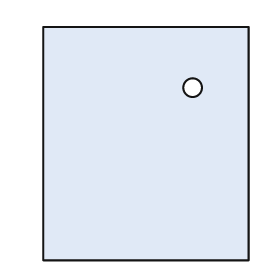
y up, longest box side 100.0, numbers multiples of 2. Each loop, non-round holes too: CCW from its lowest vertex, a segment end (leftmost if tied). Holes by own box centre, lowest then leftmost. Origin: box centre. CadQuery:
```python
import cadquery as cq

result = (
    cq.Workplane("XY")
    .moveTo(-44.0, -50.0)
    .lineTo(44.0, -50.0)
    .lineTo(44.0, 50.0)
    .lineTo(-44.0, 50.0)
    .close()
    .moveTo(20.0, 24.0)
    .circle(4.0)
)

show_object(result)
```